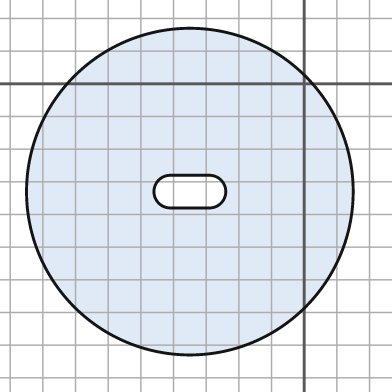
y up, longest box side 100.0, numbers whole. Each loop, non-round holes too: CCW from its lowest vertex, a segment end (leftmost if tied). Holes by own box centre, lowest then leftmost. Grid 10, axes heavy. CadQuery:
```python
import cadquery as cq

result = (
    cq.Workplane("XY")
    .moveTo(-35.0, -33.0)
    .circle(50.0)
    .moveTo(-41.0, -38.0)
    .lineTo(-29.0, -38.0)
    .threePointArc((-24.0, -33.0), (-29.0, -28.0))
    .lineTo(-41.0, -28.0)
    .threePointArc((-46.0, -33.0), (-41.0, -38.0))
    .close()
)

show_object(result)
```